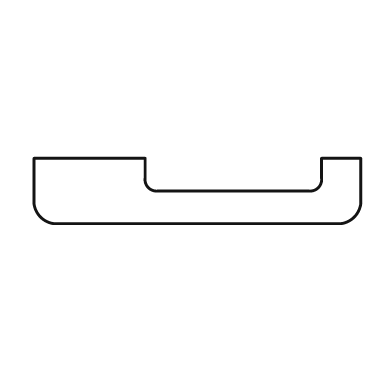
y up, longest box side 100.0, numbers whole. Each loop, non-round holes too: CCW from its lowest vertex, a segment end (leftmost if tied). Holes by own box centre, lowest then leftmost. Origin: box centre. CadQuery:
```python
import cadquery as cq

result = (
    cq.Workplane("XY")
    .moveTo(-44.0, -10.0)
    .lineTo(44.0, -10.0)
    .threePointArc((48.0, -8.0), (50.0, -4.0))
    .lineTo(50.0, 10.0)
    .lineTo(38.0, 10.0)
    .lineTo(38.0, 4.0)
    .threePointArc((37.0, 1.0), (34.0, 0.0))
    .lineTo(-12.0, 0.0)
    .threePointArc((-15.0, 1.0), (-16.0, 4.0))
    .lineTo(-16.0, 10.0)
    .lineTo(-50.0, 10.0)
    .lineTo(-50.0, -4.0)
    .threePointArc((-48.0, -8.0), (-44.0, -10.0))
    .close()
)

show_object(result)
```